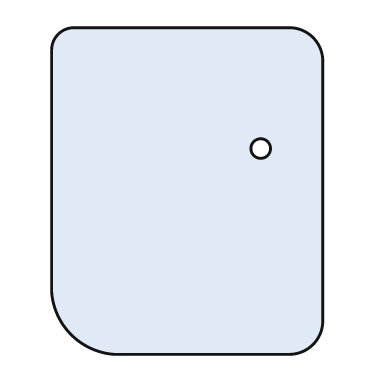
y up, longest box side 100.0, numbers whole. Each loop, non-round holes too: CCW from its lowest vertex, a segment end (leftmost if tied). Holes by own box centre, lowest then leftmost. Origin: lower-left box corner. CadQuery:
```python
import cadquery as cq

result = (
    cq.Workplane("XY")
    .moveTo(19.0, 0.0)
    .lineTo(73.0, 0.0)
    .threePointArc((80.0, 3.0), (83.0, 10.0))
    .lineTo(83.0, 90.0)
    .threePointArc((80.0, 97.0), (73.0, 100.0))
    .lineTo(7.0, 100.0)
    .threePointArc((2.0, 98.0), (0.0, 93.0))
    .lineTo(0.0, 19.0)
    .threePointArc((6.0, 6.0), (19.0, 0.0))
    .close()
    .moveTo(64.0, 63.0)
    .circle(3.0)
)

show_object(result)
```